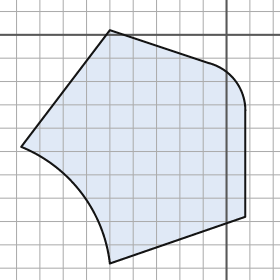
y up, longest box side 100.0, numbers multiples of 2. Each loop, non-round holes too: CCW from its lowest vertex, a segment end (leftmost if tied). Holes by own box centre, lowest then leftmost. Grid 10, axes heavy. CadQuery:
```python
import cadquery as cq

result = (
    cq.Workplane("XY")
    .moveTo(-50.0, -98.0)
    .lineTo(8.0, -78.0)
    .lineTo(8.0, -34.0)
    .threePointArc((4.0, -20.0), (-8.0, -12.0))
    .lineTo(-50.0, 2.0)
    .lineTo(-88.0, -48.0)
    .threePointArc((-62.0, -68.0), (-50.0, -98.0))
    .close()
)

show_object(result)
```